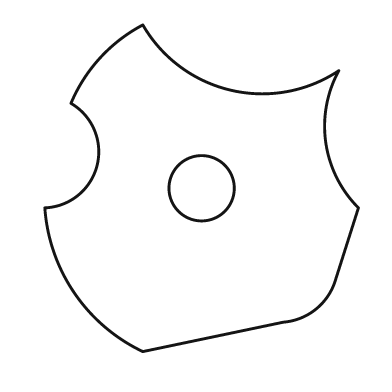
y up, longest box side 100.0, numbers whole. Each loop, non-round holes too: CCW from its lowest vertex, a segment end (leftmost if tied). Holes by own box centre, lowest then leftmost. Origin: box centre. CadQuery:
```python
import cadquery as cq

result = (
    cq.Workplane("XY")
    .moveTo(-18.0, -50.0)
    .lineTo(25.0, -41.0)
    .threePointArc((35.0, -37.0), (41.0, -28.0))
    .lineTo(48.0, -6.0)
    .threePointArc((38.0, 14.0), (42.0, 36.0))
    .threePointArc((9.0, 30.0), (-18.0, 50.0))
    .threePointArc((-31.0, 40.0), (-40.0, 26.0))
    .threePointArc((-32.0, 7.0), (-48.0, -6.0))
    .threePointArc((-39.0, -32.0), (-18.0, -50.0))
    .close()
    .moveTo(0.0, 0.0)
    .circle(10.0)
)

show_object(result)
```